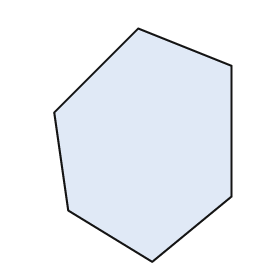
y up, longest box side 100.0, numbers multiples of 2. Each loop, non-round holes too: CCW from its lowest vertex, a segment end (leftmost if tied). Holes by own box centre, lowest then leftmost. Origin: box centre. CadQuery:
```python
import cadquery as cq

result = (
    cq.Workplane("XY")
    .moveTo(4.0, -50.0)
    .lineTo(38.0, -22.0)
    .lineTo(38.0, 34.0)
    .lineTo(-2.0, 50.0)
    .lineTo(-38.0, 14.0)
    .lineTo(-32.0, -28.0)
    .close()
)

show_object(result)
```